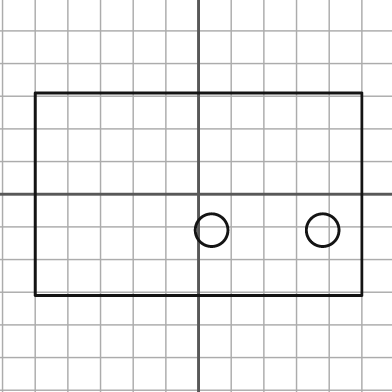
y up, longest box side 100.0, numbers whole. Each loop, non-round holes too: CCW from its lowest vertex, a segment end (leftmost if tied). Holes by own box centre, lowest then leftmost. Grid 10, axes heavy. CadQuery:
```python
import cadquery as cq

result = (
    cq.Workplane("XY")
    .moveTo(-50.0, -31.0)
    .lineTo(50.0, -31.0)
    .lineTo(50.0, 31.0)
    .lineTo(-50.0, 31.0)
    .close()
    .moveTo(4.0, -11.0)
    .circle(5.0)
    .moveTo(38.0, -11.0)
    .circle(5.0)
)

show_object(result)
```